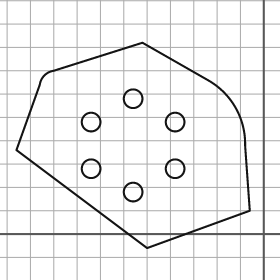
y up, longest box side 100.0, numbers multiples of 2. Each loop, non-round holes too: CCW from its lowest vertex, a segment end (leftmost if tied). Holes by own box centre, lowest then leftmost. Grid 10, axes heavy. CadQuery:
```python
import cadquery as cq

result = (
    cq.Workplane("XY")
    .moveTo(-50.0, -6.0)
    .lineTo(-6.0, 10.0)
    .lineTo(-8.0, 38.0)
    .threePointArc((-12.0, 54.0), (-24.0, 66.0))
    .lineTo(-52.0, 82.0)
    .lineTo(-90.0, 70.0)
    .threePointArc((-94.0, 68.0), (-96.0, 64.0))
    .lineTo(-106.0, 36.0)
    .close()
    .moveTo(-56.0, 18.0)
    .circle(4.0)
    .moveTo(-74.0, 28.0)
    .circle(4.0)
    .moveTo(-38.0, 28.0)
    .circle(4.0)
    .moveTo(-74.0, 48.0)
    .circle(4.0)
    .moveTo(-38.0, 48.0)
    .circle(4.0)
    .moveTo(-56.0, 58.0)
    .circle(4.0)
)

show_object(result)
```